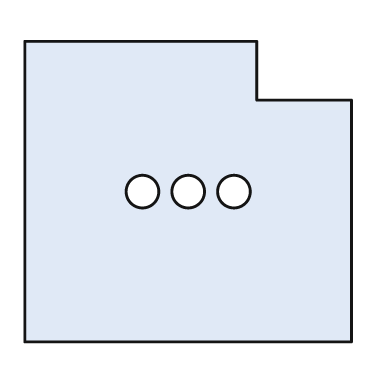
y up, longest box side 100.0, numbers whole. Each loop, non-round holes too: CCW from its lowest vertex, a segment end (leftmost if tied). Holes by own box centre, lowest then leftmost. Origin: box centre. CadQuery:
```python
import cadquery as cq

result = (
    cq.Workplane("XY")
    .moveTo(-50.0, -46.0)
    .lineTo(50.0, -46.0)
    .lineTo(50.0, 28.0)
    .lineTo(21.0, 28.0)
    .lineTo(21.0, 46.0)
    .lineTo(-50.0, 46.0)
    .close()
    .moveTo(-14.0, 0.0)
    .circle(5.0)
    .moveTo(0.0, 0.0)
    .circle(5.0)
    .moveTo(14.0, 0.0)
    .circle(5.0)
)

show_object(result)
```